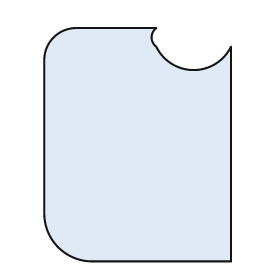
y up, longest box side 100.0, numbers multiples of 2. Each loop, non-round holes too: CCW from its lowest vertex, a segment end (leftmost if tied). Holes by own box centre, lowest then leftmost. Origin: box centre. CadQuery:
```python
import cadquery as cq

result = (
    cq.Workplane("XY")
    .moveTo(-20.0, -50.0)
    .lineTo(40.0, -50.0)
    .lineTo(40.0, 42.0)
    .threePointArc((24.0, 32.0), (8.0, 42.0))
    .threePointArc((6.0, 46.0), (8.0, 50.0))
    .lineTo(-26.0, 50.0)
    .threePointArc((-36.0, 46.0), (-40.0, 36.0))
    .lineTo(-40.0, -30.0)
    .threePointArc((-34.0, -44.0), (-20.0, -50.0))
    .close()
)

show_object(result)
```